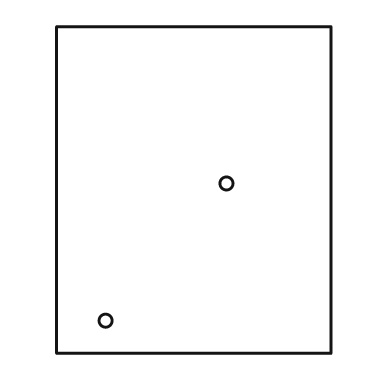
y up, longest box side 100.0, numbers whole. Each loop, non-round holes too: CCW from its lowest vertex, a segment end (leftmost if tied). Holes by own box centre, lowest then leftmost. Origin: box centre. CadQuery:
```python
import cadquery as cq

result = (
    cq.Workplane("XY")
    .moveTo(-42.0, -50.0)
    .lineTo(42.0, -50.0)
    .lineTo(42.0, 50.0)
    .lineTo(-42.0, 50.0)
    .close()
    .moveTo(-27.0, -40.0)
    .circle(2.0)
    .moveTo(10.0, 2.0)
    .circle(2.0)
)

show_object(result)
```